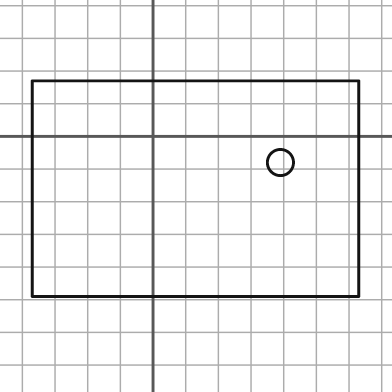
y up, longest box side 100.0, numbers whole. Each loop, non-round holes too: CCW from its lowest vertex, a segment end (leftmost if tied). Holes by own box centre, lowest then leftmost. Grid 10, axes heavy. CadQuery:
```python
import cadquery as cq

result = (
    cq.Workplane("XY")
    .moveTo(-37.0, -49.0)
    .lineTo(63.0, -49.0)
    .lineTo(63.0, 17.0)
    .lineTo(-37.0, 17.0)
    .close()
    .moveTo(39.0, -8.0)
    .circle(4.0)
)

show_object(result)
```